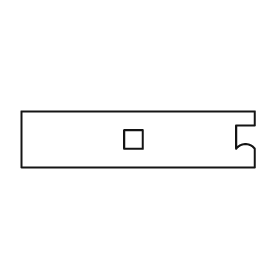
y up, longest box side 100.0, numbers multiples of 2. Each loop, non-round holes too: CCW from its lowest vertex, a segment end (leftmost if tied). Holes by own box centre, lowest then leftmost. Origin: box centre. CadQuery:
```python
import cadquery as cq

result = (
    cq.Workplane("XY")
    .moveTo(-50.0, -12.0)
    .lineTo(50.0, -12.0)
    .lineTo(50.0, -4.0)
    .threePointArc((46.0, -2.0), (42.0, -4.0))
    .lineTo(42.0, 6.0)
    .lineTo(50.0, 6.0)
    .lineTo(50.0, 12.0)
    .lineTo(-50.0, 12.0)
    .close()
    .moveTo(-6.0, -4.0)
    .lineTo(2.0, -4.0)
    .lineTo(2.0, 4.0)
    .lineTo(-6.0, 4.0)
    .close()
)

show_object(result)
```